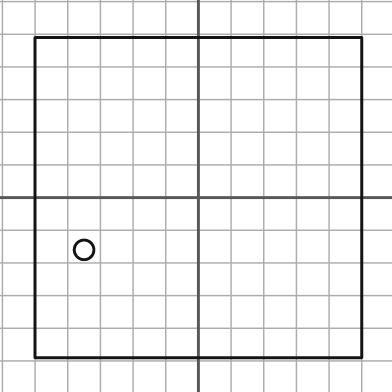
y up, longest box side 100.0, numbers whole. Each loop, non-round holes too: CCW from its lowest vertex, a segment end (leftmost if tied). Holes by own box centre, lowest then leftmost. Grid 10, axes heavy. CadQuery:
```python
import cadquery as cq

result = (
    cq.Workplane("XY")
    .moveTo(-50.0, -49.0)
    .lineTo(50.0, -49.0)
    .lineTo(50.0, 49.0)
    .lineTo(-50.0, 49.0)
    .close()
    .moveTo(-35.0, -16.0)
    .circle(3.0)
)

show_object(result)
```